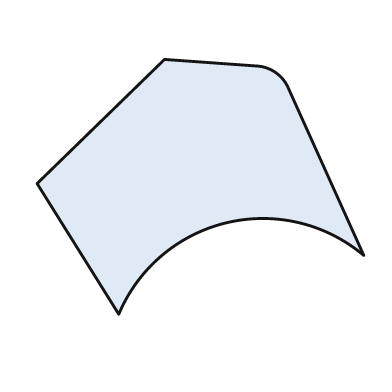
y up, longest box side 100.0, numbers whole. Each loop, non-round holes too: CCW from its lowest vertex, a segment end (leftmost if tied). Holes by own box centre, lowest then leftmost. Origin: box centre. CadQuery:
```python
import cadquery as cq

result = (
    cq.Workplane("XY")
    .moveTo(-25.0, -39.0)
    .threePointArc((8.0, -11.0), (50.0, -21.0))
    .lineTo(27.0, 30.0)
    .threePointArc((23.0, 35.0), (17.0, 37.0))
    .lineTo(-11.0, 39.0)
    .lineTo(-50.0, 1.0)
    .close()
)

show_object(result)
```